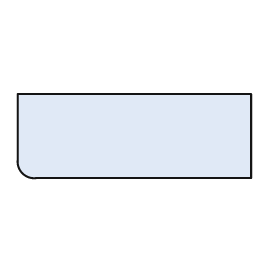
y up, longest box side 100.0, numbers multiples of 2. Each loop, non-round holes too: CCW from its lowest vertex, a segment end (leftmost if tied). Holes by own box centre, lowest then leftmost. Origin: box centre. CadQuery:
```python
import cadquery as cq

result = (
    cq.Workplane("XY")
    .moveTo(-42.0, -18.0)
    .lineTo(50.0, -18.0)
    .lineTo(50.0, 18.0)
    .lineTo(-50.0, 18.0)
    .lineTo(-50.0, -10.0)
    .threePointArc((-48.0, -16.0), (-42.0, -18.0))
    .close()
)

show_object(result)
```